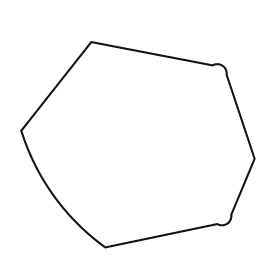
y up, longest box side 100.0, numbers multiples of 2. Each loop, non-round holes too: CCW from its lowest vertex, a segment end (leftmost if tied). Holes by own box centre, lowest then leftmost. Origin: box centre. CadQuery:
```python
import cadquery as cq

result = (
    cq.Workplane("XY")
    .moveTo(-14.0, -44.0)
    .lineTo(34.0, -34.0)
    .threePointArc((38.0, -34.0), (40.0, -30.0))
    .lineTo(50.0, -6.0)
    .lineTo(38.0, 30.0)
    .threePointArc((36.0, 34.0), (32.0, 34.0))
    .lineTo(-20.0, 44.0)
    .lineTo(-50.0, 6.0)
    .threePointArc((-36.0, -22.0), (-14.0, -44.0))
    .close()
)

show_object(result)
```